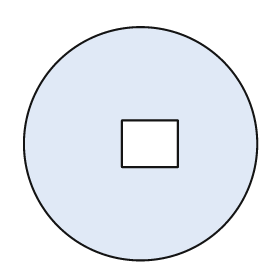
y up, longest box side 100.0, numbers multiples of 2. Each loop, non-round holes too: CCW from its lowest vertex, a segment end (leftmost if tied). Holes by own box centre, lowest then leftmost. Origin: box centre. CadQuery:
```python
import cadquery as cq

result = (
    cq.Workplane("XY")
    .moveTo(0.0, 0.0)
    .circle(50.0)
    .moveTo(-8.0, -10.0)
    .lineTo(16.0, -10.0)
    .lineTo(16.0, 10.0)
    .lineTo(-8.0, 10.0)
    .close()
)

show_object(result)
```